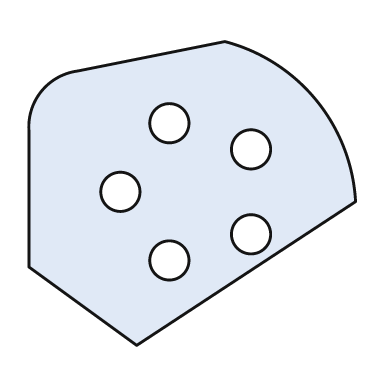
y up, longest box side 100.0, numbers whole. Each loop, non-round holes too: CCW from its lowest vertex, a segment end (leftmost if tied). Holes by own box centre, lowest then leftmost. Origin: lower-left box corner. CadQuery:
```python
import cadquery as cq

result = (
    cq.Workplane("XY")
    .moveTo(33.0, 0.0)
    .lineTo(100.0, 44.0)
    .threePointArc((88.0, 75.0), (60.0, 93.0))
    .lineTo(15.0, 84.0)
    .threePointArc((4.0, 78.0), (0.0, 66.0))
    .lineTo(0.0, 24.0)
    .close()
    .moveTo(43.0, 26.0)
    .circle(6.0)
    .moveTo(68.0, 34.0)
    .circle(6.0)
    .moveTo(28.0, 47.0)
    .circle(6.0)
    .moveTo(68.0, 60.0)
    .circle(6.0)
    .moveTo(43.0, 68.0)
    .circle(6.0)
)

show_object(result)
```